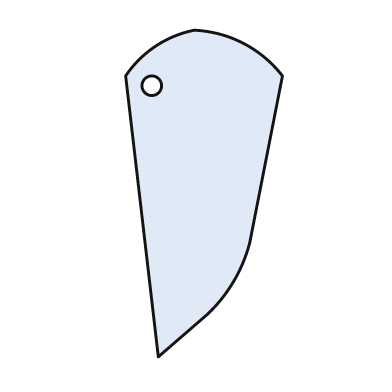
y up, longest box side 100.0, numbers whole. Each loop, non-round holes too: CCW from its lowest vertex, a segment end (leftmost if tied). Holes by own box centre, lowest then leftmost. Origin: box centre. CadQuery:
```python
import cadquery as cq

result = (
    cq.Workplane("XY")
    .moveTo(-14.0, -50.0)
    .lineTo(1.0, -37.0)
    .threePointArc((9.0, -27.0), (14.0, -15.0))
    .lineTo(24.0, 36.0)
    .threePointArc((12.0, 46.0), (-3.0, 50.0))
    .threePointArc((-15.0, 45.0), (-24.0, 36.0))
    .close()
    .moveTo(-16.0, 33.0)
    .circle(3.0)
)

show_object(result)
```